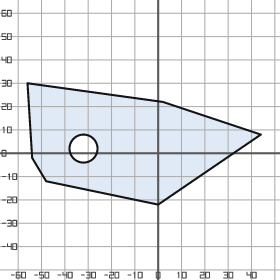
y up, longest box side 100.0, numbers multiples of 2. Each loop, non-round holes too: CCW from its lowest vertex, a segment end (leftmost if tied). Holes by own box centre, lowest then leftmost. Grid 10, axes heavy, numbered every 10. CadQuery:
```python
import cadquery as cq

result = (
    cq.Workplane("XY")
    .moveTo(0.0, -22.0)
    .lineTo(44.0, 8.0)
    .lineTo(2.0, 22.0)
    .lineTo(-56.0, 30.0)
    .lineTo(-54.0, -2.0)
    .lineTo(-48.0, -12.0)
    .close()
    .moveTo(-32.0, 2.0)
    .circle(6.0)
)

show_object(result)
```